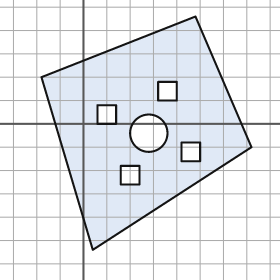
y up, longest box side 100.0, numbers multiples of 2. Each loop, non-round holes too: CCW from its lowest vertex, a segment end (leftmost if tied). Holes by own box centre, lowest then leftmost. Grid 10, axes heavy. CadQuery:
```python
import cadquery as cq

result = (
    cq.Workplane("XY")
    .moveTo(4.0, -54.0)
    .lineTo(72.0, -10.0)
    .lineTo(48.0, 46.0)
    .lineTo(-18.0, 20.0)
    .close()
    .moveTo(16.0, -26.0)
    .lineTo(24.0, -26.0)
    .lineTo(24.0, -18.0)
    .lineTo(16.0, -18.0)
    .close()
    .moveTo(42.0, -16.0)
    .lineTo(50.0, -16.0)
    .lineTo(50.0, -8.0)
    .lineTo(42.0, -8.0)
    .close()
    .moveTo(28.0, -4.0)
    .circle(8.0)
    .moveTo(6.0, 0.0)
    .lineTo(14.0, 0.0)
    .lineTo(14.0, 8.0)
    .lineTo(6.0, 8.0)
    .close()
    .moveTo(32.0, 10.0)
    .lineTo(40.0, 10.0)
    .lineTo(40.0, 18.0)
    .lineTo(32.0, 18.0)
    .close()
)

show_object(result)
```